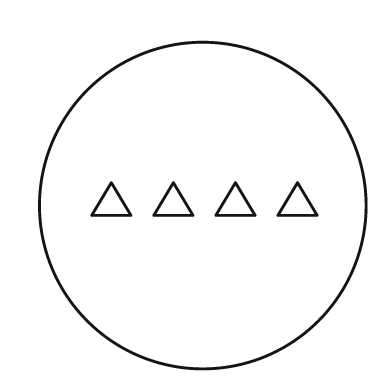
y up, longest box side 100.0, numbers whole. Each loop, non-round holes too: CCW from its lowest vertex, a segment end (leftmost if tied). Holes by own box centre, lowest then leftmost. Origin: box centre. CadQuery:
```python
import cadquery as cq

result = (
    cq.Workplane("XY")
    .moveTo(0.0, 0.0)
    .circle(50.0)
    .moveTo(-34.0, -3.0)
    .lineTo(-22.0, -3.0)
    .lineTo(-28.0, 7.0)
    .close()
    .moveTo(-15.0, -3.0)
    .lineTo(-3.0, -3.0)
    .lineTo(-9.0, 7.0)
    .close()
    .moveTo(4.0, -3.0)
    .lineTo(16.0, -3.0)
    .lineTo(10.0, 7.0)
    .close()
    .moveTo(23.0, -3.0)
    .lineTo(35.0, -3.0)
    .lineTo(29.0, 7.0)
    .close()
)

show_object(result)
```